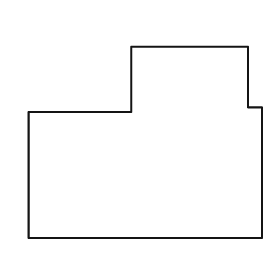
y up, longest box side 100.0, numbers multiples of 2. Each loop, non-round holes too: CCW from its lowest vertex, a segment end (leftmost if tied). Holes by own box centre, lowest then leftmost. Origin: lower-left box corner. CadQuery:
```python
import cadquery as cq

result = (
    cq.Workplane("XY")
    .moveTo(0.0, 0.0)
    .lineTo(100.0, 0.0)
    .lineTo(100.0, 56.0)
    .lineTo(94.0, 56.0)
    .lineTo(94.0, 82.0)
    .lineTo(44.0, 82.0)
    .lineTo(44.0, 54.0)
    .lineTo(0.0, 54.0)
    .close()
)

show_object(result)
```